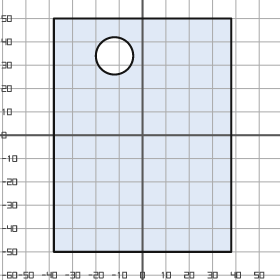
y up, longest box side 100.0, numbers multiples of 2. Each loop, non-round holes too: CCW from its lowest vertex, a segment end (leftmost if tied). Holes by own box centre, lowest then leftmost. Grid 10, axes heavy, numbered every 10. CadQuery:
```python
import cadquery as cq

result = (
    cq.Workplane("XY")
    .moveTo(-38.0, -50.0)
    .lineTo(38.0, -50.0)
    .lineTo(38.0, 50.0)
    .lineTo(-38.0, 50.0)
    .close()
    .moveTo(-12.0, 34.0)
    .circle(8.0)
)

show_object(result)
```